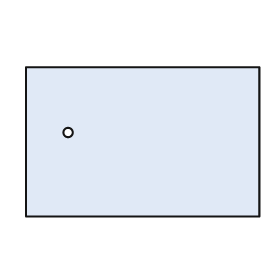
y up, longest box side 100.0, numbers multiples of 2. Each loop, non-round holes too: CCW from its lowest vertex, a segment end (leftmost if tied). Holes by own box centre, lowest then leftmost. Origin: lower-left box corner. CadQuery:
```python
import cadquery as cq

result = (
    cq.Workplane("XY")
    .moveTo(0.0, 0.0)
    .lineTo(100.0, 0.0)
    .lineTo(100.0, 64.0)
    .lineTo(0.0, 64.0)
    .close()
    .moveTo(18.0, 36.0)
    .circle(2.0)
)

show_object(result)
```